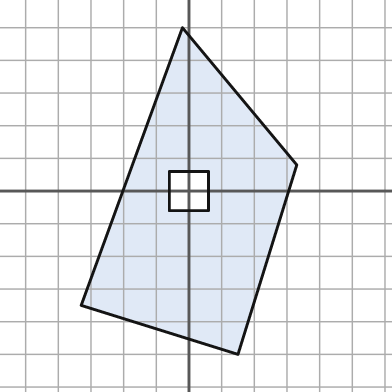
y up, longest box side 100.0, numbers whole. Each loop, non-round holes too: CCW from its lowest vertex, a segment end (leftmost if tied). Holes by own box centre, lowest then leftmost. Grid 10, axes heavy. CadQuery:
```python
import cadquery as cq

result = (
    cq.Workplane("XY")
    .moveTo(15.0, -50.0)
    .lineTo(33.0, 8.0)
    .lineTo(-2.0, 50.0)
    .lineTo(-33.0, -35.0)
    .close()
    .moveTo(-6.0, -6.0)
    .lineTo(6.0, -6.0)
    .lineTo(6.0, 6.0)
    .lineTo(-6.0, 6.0)
    .close()
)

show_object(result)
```